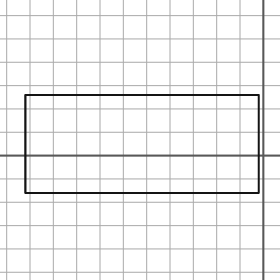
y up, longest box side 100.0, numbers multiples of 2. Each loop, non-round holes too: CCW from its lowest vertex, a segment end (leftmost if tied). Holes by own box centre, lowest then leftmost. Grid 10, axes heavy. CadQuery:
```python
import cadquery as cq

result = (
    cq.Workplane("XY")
    .moveTo(-102.0, -16.0)
    .lineTo(-2.0, -16.0)
    .lineTo(-2.0, 26.0)
    .lineTo(-102.0, 26.0)
    .close()
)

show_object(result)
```